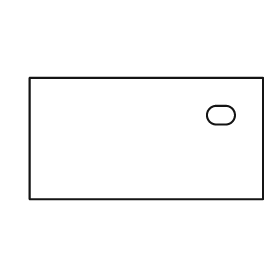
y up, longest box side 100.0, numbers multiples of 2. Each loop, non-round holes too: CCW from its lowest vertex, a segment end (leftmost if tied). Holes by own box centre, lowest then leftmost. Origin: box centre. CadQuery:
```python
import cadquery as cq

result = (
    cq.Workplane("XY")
    .moveTo(-50.0, -26.0)
    .lineTo(50.0, -26.0)
    .lineTo(50.0, 26.0)
    .lineTo(-50.0, 26.0)
    .close()
    .moveTo(30.0, 6.0)
    .lineTo(34.0, 6.0)
    .threePointArc((38.0, 10.0), (34.0, 14.0))
    .lineTo(30.0, 14.0)
    .threePointArc((26.0, 10.0), (30.0, 6.0))
    .close()
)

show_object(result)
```